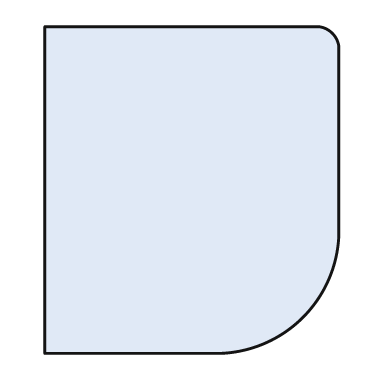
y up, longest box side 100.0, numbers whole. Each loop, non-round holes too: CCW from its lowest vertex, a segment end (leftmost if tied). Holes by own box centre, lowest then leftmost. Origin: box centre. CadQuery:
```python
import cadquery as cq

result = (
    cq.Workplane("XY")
    .moveTo(-45.0, -50.0)
    .lineTo(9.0, -50.0)
    .threePointArc((34.0, -39.0), (45.0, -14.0))
    .lineTo(45.0, 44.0)
    .threePointArc((43.0, 48.0), (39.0, 50.0))
    .lineTo(-45.0, 50.0)
    .close()
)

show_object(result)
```